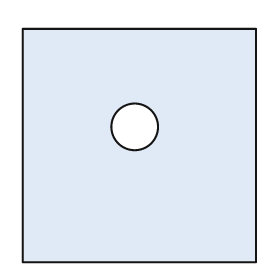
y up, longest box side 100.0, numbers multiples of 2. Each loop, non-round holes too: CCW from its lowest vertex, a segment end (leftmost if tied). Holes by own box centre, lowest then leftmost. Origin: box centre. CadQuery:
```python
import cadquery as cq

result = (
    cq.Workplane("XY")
    .moveTo(-50.0, -50.0)
    .lineTo(50.0, -50.0)
    .lineTo(50.0, 50.0)
    .lineTo(-50.0, 50.0)
    .close()
    .moveTo(-2.0, 8.0)
    .circle(10.0)
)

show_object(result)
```